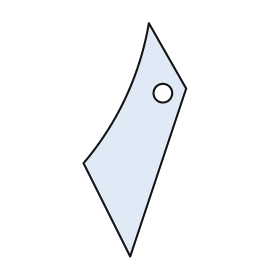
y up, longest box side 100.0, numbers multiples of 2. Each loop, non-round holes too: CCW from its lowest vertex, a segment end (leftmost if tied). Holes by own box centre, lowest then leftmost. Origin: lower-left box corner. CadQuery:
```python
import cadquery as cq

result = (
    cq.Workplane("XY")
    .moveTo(20.0, 0.0)
    .lineTo(44.0, 72.0)
    .lineTo(28.0, 100.0)
    .threePointArc((18.0, 68.0), (0.0, 40.0))
    .close()
    .moveTo(34.0, 70.0)
    .circle(4.0)
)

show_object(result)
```